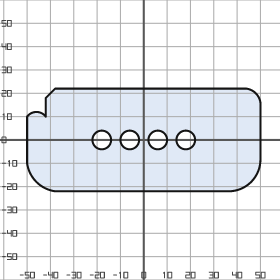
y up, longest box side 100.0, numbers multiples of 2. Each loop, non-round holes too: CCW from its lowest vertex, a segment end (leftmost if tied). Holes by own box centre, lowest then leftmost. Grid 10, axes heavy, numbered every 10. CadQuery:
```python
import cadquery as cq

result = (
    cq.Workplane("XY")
    .moveTo(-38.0, -22.0)
    .lineTo(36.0, -22.0)
    .threePointArc((46.0, -18.0), (50.0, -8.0))
    .lineTo(50.0, 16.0)
    .threePointArc((48.0, 20.0), (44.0, 22.0))
    .lineTo(-38.0, 22.0)
    .lineTo(-42.0, 18.0)
    .lineTo(-42.0, 10.0)
    .threePointArc((-46.0, 12.0), (-50.0, 10.0))
    .lineTo(-50.0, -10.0)
    .threePointArc((-46.0, -18.0), (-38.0, -22.0))
    .close()
    .moveTo(-18.0, 0.0)
    .circle(4.0)
    .moveTo(-6.0, 0.0)
    .circle(4.0)
    .moveTo(6.0, 0.0)
    .circle(4.0)
    .moveTo(18.0, 0.0)
    .circle(4.0)
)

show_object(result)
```